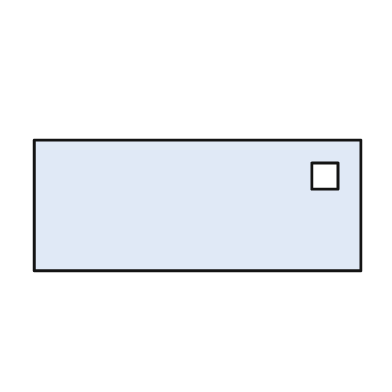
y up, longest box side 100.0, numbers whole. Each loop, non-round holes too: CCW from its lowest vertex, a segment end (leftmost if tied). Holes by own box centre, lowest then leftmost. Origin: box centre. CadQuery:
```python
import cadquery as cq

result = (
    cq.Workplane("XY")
    .moveTo(-50.0, -20.0)
    .lineTo(50.0, -20.0)
    .lineTo(50.0, 20.0)
    .lineTo(-50.0, 20.0)
    .close()
    .moveTo(35.0, 5.0)
    .lineTo(43.0, 5.0)
    .lineTo(43.0, 13.0)
    .lineTo(35.0, 13.0)
    .close()
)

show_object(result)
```